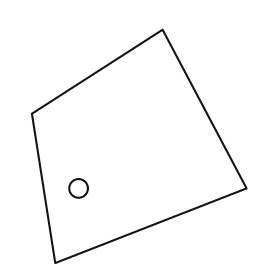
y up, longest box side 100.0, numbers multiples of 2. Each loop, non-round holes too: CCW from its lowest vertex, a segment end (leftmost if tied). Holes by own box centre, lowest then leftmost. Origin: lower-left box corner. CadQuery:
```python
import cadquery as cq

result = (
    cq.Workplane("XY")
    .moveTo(10.0, 0.0)
    .lineTo(92.0, 32.0)
    .lineTo(56.0, 100.0)
    .lineTo(0.0, 64.0)
    .close()
    .moveTo(20.0, 32.0)
    .circle(4.0)
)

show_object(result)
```